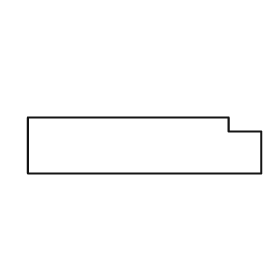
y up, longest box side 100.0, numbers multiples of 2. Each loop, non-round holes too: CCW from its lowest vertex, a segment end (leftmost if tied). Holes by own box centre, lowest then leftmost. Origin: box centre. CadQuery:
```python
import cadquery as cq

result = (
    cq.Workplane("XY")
    .moveTo(-50.0, -12.0)
    .lineTo(50.0, -12.0)
    .lineTo(50.0, 6.0)
    .lineTo(36.0, 6.0)
    .lineTo(36.0, 12.0)
    .lineTo(-50.0, 12.0)
    .close()
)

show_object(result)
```